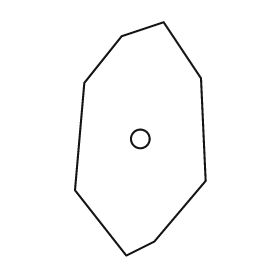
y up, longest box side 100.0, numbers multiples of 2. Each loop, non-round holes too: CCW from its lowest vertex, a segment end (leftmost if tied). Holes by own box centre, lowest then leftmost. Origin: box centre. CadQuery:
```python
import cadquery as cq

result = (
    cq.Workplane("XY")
    .moveTo(-6.0, -50.0)
    .lineTo(6.0, -44.0)
    .lineTo(28.0, -18.0)
    .lineTo(26.0, 26.0)
    .lineTo(10.0, 50.0)
    .lineTo(-8.0, 44.0)
    .lineTo(-24.0, 24.0)
    .lineTo(-28.0, -22.0)
    .close()
    .moveTo(0.0, 0.0)
    .circle(4.0)
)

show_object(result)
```